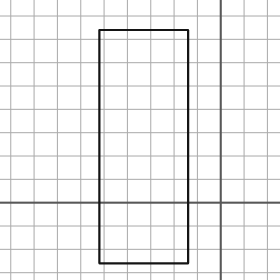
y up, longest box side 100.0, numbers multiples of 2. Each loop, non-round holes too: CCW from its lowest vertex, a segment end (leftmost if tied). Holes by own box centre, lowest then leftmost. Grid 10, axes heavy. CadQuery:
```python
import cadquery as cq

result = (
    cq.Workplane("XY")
    .moveTo(-52.0, -26.0)
    .lineTo(-14.0, -26.0)
    .lineTo(-14.0, 74.0)
    .lineTo(-52.0, 74.0)
    .close()
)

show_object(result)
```